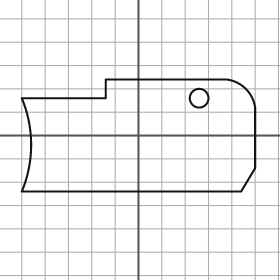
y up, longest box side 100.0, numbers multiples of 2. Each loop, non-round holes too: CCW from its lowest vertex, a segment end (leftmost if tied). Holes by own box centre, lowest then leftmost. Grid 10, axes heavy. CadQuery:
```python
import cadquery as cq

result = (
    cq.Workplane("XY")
    .moveTo(-50.0, -24.0)
    .lineTo(44.0, -24.0)
    .lineTo(50.0, -14.0)
    .lineTo(50.0, 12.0)
    .threePointArc((46.0, 20.0), (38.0, 24.0))
    .lineTo(-14.0, 24.0)
    .lineTo(-14.0, 16.0)
    .lineTo(-50.0, 16.0)
    .threePointArc((-46.0, -4.0), (-50.0, -24.0))
    .close()
    .moveTo(26.0, 16.0)
    .circle(4.0)
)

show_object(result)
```